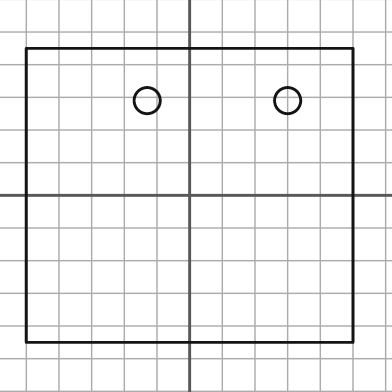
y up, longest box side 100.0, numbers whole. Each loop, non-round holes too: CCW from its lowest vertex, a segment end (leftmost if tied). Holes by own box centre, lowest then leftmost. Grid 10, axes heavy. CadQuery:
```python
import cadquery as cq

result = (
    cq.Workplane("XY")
    .moveTo(-50.0, -45.0)
    .lineTo(50.0, -45.0)
    .lineTo(50.0, 45.0)
    .lineTo(-50.0, 45.0)
    .close()
    .moveTo(-13.0, 29.0)
    .circle(4.0)
    .moveTo(30.0, 29.0)
    .circle(4.0)
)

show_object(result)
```